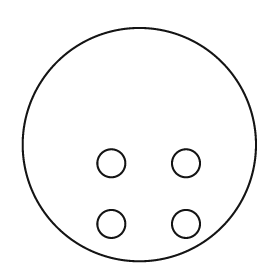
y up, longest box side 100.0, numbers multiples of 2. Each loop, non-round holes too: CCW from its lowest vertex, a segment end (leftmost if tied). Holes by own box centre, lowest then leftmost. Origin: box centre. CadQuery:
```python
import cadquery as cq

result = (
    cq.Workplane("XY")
    .moveTo(0.0, 0.0)
    .circle(50.0)
    .moveTo(-12.0, -34.0)
    .circle(6.0)
    .moveTo(20.0, -34.0)
    .circle(6.0)
    .moveTo(-12.0, -8.0)
    .circle(6.0)
    .moveTo(20.0, -8.0)
    .circle(6.0)
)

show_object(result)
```